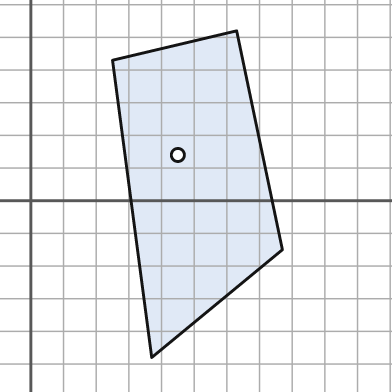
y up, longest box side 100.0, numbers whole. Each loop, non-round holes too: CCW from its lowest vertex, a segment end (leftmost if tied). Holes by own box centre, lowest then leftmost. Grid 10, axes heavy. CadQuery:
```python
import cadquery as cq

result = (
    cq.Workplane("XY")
    .moveTo(37.0, -48.0)
    .lineTo(77.0, -15.0)
    .lineTo(63.0, 52.0)
    .lineTo(25.0, 43.0)
    .close()
    .moveTo(45.0, 14.0)
    .circle(2.0)
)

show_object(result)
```